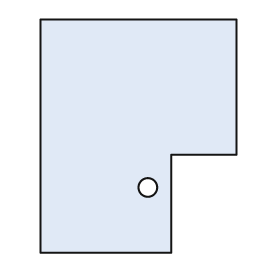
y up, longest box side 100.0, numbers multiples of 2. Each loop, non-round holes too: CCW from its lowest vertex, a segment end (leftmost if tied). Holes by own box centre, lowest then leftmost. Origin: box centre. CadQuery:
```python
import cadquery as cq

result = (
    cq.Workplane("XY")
    .moveTo(-42.0, -50.0)
    .lineTo(14.0, -50.0)
    .lineTo(14.0, -8.0)
    .lineTo(42.0, -8.0)
    .lineTo(42.0, 50.0)
    .lineTo(-42.0, 50.0)
    .close()
    .moveTo(4.0, -22.0)
    .circle(4.0)
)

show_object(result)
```